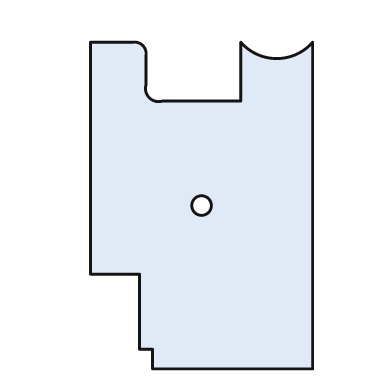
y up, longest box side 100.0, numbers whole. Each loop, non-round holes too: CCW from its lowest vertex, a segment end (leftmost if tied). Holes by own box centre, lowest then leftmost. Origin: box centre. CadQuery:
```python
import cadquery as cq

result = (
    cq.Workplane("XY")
    .moveTo(-15.0, -50.0)
    .lineTo(34.0, -50.0)
    .lineTo(34.0, 50.0)
    .threePointArc((23.0, 45.0), (12.0, 50.0))
    .lineTo(12.0, 32.0)
    .lineTo(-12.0, 32.0)
    .threePointArc((-16.0, 33.0), (-17.0, 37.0))
    .lineTo(-17.0, 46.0)
    .threePointArc((-18.0, 49.0), (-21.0, 50.0))
    .lineTo(-34.0, 50.0)
    .lineTo(-34.0, -21.0)
    .lineTo(-19.0, -21.0)
    .lineTo(-19.0, -44.0)
    .lineTo(-15.0, -44.0)
    .close()
    .moveTo(0.0, 0.0)
    .circle(3.0)
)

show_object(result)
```